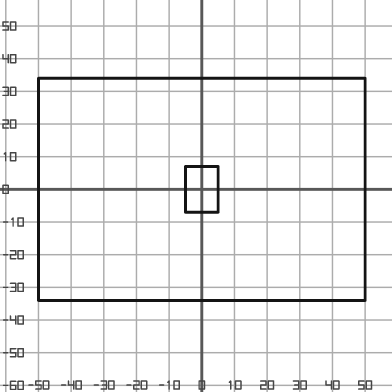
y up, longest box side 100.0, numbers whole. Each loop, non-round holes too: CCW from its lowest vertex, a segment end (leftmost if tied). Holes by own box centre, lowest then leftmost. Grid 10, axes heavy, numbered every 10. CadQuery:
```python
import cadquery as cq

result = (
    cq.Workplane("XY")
    .moveTo(-50.0, -34.0)
    .lineTo(50.0, -34.0)
    .lineTo(50.0, 34.0)
    .lineTo(-50.0, 34.0)
    .close()
    .moveTo(-5.0, -7.0)
    .lineTo(5.0, -7.0)
    .lineTo(5.0, 7.0)
    .lineTo(-5.0, 7.0)
    .close()
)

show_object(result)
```